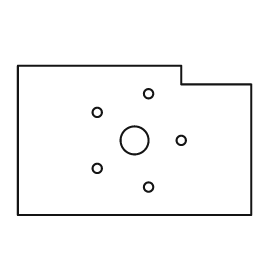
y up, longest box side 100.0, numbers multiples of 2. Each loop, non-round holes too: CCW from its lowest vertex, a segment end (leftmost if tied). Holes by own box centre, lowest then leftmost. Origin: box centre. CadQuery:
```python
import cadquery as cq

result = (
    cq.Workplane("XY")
    .moveTo(-50.0, -32.0)
    .lineTo(50.0, -32.0)
    .lineTo(50.0, 24.0)
    .lineTo(20.0, 24.0)
    .lineTo(20.0, 32.0)
    .lineTo(-50.0, 32.0)
    .close()
    .moveTo(6.0, -20.0)
    .circle(2.0)
    .moveTo(-16.0, -12.0)
    .circle(2.0)
    .moveTo(0.0, 0.0)
    .circle(6.0)
    .moveTo(20.0, 0.0)
    .circle(2.0)
    .moveTo(-16.0, 12.0)
    .circle(2.0)
    .moveTo(6.0, 20.0)
    .circle(2.0)
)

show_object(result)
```